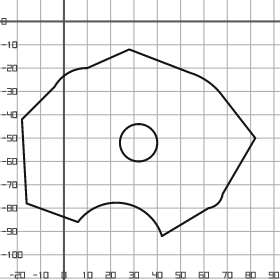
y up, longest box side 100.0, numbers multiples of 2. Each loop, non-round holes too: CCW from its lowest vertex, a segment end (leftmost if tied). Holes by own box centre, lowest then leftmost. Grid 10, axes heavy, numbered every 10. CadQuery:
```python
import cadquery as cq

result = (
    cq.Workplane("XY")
    .moveTo(42.0, -92.0)
    .lineTo(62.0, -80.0)
    .threePointArc((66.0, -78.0), (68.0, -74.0))
    .lineTo(82.0, -50.0)
    .lineTo(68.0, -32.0)
    .threePointArc((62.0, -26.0), (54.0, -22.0))
    .lineTo(28.0, -12.0)
    .lineTo(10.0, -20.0)
    .threePointArc((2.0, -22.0), (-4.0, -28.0))
    .lineTo(-18.0, -42.0)
    .lineTo(-16.0, -78.0)
    .lineTo(6.0, -86.0)
    .threePointArc((26.0, -78.0), (42.0, -92.0))
    .close()
    .moveTo(32.0, -52.0)
    .circle(8.0)
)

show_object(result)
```